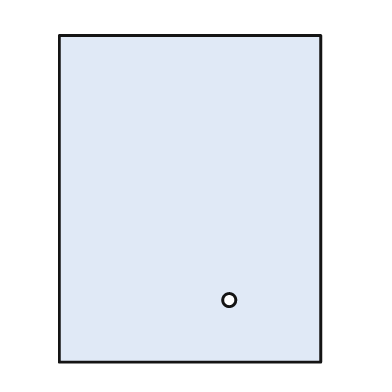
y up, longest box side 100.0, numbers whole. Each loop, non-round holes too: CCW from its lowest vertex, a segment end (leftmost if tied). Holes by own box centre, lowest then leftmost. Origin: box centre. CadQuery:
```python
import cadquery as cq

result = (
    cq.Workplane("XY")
    .moveTo(-40.0, -50.0)
    .lineTo(40.0, -50.0)
    .lineTo(40.0, 50.0)
    .lineTo(-40.0, 50.0)
    .close()
    .moveTo(12.0, -31.0)
    .circle(2.0)
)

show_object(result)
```